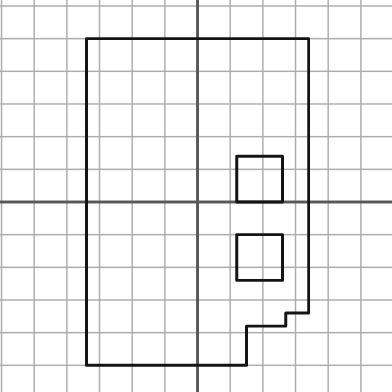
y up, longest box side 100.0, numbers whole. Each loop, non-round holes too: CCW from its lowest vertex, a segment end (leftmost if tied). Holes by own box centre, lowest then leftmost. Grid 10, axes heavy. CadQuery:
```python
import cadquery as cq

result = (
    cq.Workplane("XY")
    .moveTo(-34.0, -50.0)
    .lineTo(15.0, -50.0)
    .lineTo(15.0, -38.0)
    .lineTo(27.0, -38.0)
    .lineTo(27.0, -34.0)
    .lineTo(34.0, -34.0)
    .lineTo(34.0, 50.0)
    .lineTo(-34.0, 50.0)
    .close()
    .moveTo(12.0, -24.0)
    .lineTo(26.0, -24.0)
    .lineTo(26.0, -10.0)
    .lineTo(12.0, -10.0)
    .close()
    .moveTo(12.0, 0.0)
    .lineTo(26.0, 0.0)
    .lineTo(26.0, 14.0)
    .lineTo(12.0, 14.0)
    .close()
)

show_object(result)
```